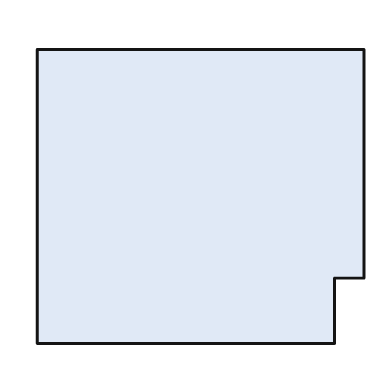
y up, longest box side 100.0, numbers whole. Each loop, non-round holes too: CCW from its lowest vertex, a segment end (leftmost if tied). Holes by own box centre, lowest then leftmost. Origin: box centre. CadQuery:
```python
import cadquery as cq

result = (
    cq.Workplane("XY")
    .moveTo(-50.0, -45.0)
    .lineTo(41.0, -45.0)
    .lineTo(41.0, -25.0)
    .lineTo(50.0, -25.0)
    .lineTo(50.0, 45.0)
    .lineTo(-50.0, 45.0)
    .close()
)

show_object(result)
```